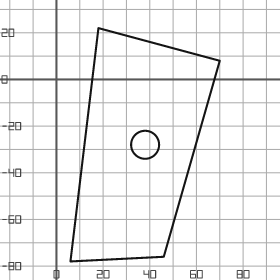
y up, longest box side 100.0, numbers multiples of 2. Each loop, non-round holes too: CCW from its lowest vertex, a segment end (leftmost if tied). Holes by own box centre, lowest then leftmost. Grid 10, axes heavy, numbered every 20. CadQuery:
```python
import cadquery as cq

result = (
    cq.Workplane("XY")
    .moveTo(6.0, -78.0)
    .lineTo(46.0, -76.0)
    .lineTo(70.0, 8.0)
    .lineTo(18.0, 22.0)
    .close()
    .moveTo(38.0, -28.0)
    .circle(6.0)
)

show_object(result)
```